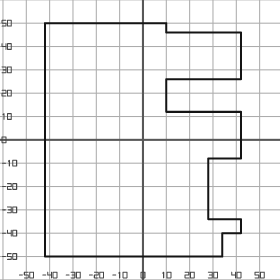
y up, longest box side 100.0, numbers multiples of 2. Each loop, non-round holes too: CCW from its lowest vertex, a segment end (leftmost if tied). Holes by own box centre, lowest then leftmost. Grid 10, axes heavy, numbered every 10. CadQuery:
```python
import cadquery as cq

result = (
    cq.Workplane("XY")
    .moveTo(-42.0, -50.0)
    .lineTo(34.0, -50.0)
    .lineTo(34.0, -40.0)
    .lineTo(42.0, -40.0)
    .lineTo(42.0, -34.0)
    .lineTo(28.0, -34.0)
    .lineTo(28.0, -8.0)
    .lineTo(42.0, -8.0)
    .lineTo(42.0, 12.0)
    .lineTo(10.0, 12.0)
    .lineTo(10.0, 26.0)
    .lineTo(42.0, 26.0)
    .lineTo(42.0, 46.0)
    .lineTo(10.0, 46.0)
    .lineTo(10.0, 50.0)
    .lineTo(-42.0, 50.0)
    .close()
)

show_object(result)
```